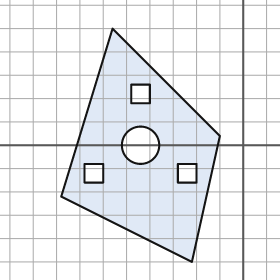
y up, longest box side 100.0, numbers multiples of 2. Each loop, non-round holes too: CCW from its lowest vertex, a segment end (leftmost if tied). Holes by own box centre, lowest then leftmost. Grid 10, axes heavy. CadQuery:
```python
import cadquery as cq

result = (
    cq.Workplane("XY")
    .moveTo(-22.0, -50.0)
    .lineTo(-10.0, 4.0)
    .lineTo(-56.0, 50.0)
    .lineTo(-78.0, -22.0)
    .close()
    .moveTo(-68.0, -16.0)
    .lineTo(-60.0, -16.0)
    .lineTo(-60.0, -8.0)
    .lineTo(-68.0, -8.0)
    .close()
    .moveTo(-28.0, -16.0)
    .lineTo(-20.0, -16.0)
    .lineTo(-20.0, -8.0)
    .lineTo(-28.0, -8.0)
    .close()
    .moveTo(-44.0, 0.0)
    .circle(8.0)
    .moveTo(-48.0, 18.0)
    .lineTo(-40.0, 18.0)
    .lineTo(-40.0, 26.0)
    .lineTo(-48.0, 26.0)
    .close()
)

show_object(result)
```